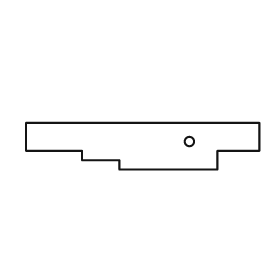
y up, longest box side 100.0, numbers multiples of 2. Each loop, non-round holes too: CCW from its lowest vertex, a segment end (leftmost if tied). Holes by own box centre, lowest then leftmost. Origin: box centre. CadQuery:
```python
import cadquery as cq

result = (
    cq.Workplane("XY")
    .moveTo(-10.0, -10.0)
    .lineTo(32.0, -10.0)
    .lineTo(32.0, -2.0)
    .lineTo(50.0, -2.0)
    .lineTo(50.0, 10.0)
    .lineTo(-50.0, 10.0)
    .lineTo(-50.0, -2.0)
    .lineTo(-26.0, -2.0)
    .lineTo(-26.0, -6.0)
    .lineTo(-10.0, -6.0)
    .close()
    .moveTo(20.0, 2.0)
    .circle(2.0)
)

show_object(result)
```